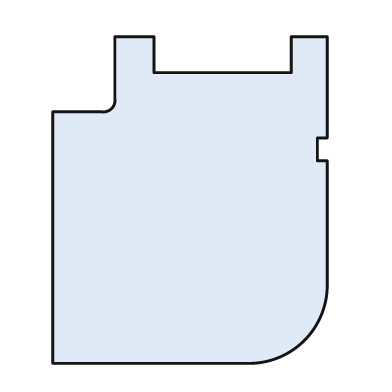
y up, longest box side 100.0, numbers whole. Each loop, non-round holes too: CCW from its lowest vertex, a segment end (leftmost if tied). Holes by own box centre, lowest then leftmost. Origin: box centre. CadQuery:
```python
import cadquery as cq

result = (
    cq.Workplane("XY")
    .moveTo(-42.0, -50.0)
    .lineTo(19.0, -50.0)
    .threePointArc((35.0, -43.0), (42.0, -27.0))
    .lineTo(42.0, 12.0)
    .lineTo(39.0, 12.0)
    .lineTo(39.0, 19.0)
    .lineTo(42.0, 19.0)
    .lineTo(42.0, 50.0)
    .lineTo(31.0, 50.0)
    .lineTo(31.0, 39.0)
    .lineTo(-11.0, 39.0)
    .lineTo(-11.0, 50.0)
    .lineTo(-23.0, 50.0)
    .lineTo(-23.0, 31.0)
    .threePointArc((-24.0, 28.0), (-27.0, 27.0))
    .lineTo(-42.0, 27.0)
    .close()
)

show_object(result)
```